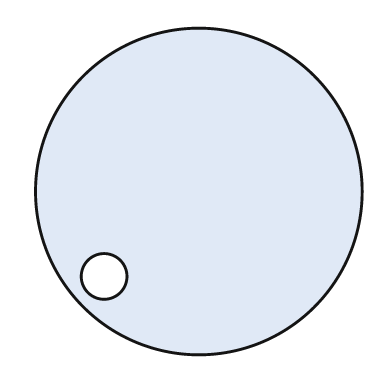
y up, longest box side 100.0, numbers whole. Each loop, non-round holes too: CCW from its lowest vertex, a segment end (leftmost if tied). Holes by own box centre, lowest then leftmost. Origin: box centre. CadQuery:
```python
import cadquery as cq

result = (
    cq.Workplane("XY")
    .moveTo(0.0, 0.0)
    .circle(50.0)
    .moveTo(-29.0, -26.0)
    .circle(7.0)
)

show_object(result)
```